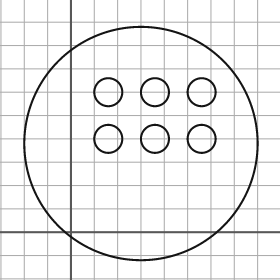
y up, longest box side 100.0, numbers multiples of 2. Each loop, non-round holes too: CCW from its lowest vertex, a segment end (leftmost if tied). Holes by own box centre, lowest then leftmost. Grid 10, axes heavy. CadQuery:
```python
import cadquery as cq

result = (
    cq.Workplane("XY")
    .moveTo(30.0, 38.0)
    .circle(50.0)
    .moveTo(16.0, 40.0)
    .circle(6.0)
    .moveTo(36.0, 40.0)
    .circle(6.0)
    .moveTo(56.0, 40.0)
    .circle(6.0)
    .moveTo(16.0, 60.0)
    .circle(6.0)
    .moveTo(36.0, 60.0)
    .circle(6.0)
    .moveTo(56.0, 60.0)
    .circle(6.0)
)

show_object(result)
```